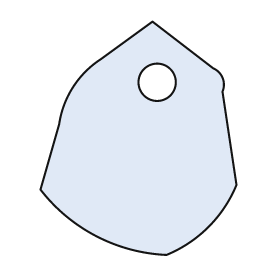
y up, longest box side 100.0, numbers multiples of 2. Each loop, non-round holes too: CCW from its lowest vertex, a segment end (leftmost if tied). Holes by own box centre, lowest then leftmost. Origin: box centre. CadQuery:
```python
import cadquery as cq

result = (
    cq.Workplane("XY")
    .moveTo(12.0, -50.0)
    .threePointArc((30.0, -38.0), (42.0, -20.0))
    .lineTo(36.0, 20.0)
    .threePointArc((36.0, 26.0), (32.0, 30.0))
    .lineTo(6.0, 50.0)
    .lineTo(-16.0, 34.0)
    .threePointArc((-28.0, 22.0), (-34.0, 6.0))
    .lineTo(-42.0, -22.0)
    .threePointArc((-18.0, -42.0), (12.0, -50.0))
    .close()
    .moveTo(8.0, 24.0)
    .circle(8.0)
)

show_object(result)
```